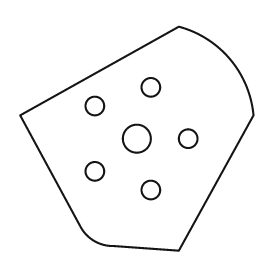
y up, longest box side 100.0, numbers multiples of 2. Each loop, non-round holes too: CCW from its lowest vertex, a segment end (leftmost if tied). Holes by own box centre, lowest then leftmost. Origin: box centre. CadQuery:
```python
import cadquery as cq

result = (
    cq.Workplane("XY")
    .moveTo(18.0, -48.0)
    .lineTo(50.0, 10.0)
    .threePointArc((40.0, 34.0), (18.0, 48.0))
    .lineTo(-50.0, 10.0)
    .lineTo(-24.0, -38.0)
    .threePointArc((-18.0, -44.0), (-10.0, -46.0))
    .close()
    .moveTo(6.0, -22.0)
    .circle(4.0)
    .moveTo(-18.0, -14.0)
    .circle(4.0)
    .moveTo(0.0, 0.0)
    .circle(6.0)
    .moveTo(22.0, 0.0)
    .circle(4.0)
    .moveTo(-18.0, 14.0)
    .circle(4.0)
    .moveTo(6.0, 22.0)
    .circle(4.0)
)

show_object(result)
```